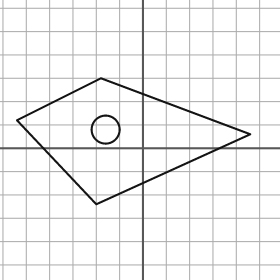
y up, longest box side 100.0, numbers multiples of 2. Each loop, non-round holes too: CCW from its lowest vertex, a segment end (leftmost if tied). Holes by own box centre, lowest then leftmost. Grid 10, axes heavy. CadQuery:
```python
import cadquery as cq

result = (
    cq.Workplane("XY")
    .moveTo(-20.0, -24.0)
    .lineTo(46.0, 6.0)
    .lineTo(-18.0, 30.0)
    .lineTo(-54.0, 12.0)
    .close()
    .moveTo(-16.0, 8.0)
    .circle(6.0)
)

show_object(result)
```